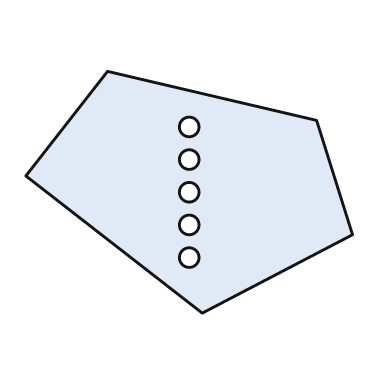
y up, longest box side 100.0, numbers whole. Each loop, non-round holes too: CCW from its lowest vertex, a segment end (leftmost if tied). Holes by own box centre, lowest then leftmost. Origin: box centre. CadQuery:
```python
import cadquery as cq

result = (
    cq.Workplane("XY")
    .moveTo(4.0, -37.0)
    .lineTo(50.0, -13.0)
    .lineTo(39.0, 22.0)
    .lineTo(-25.0, 37.0)
    .lineTo(-50.0, 5.0)
    .close()
    .moveTo(0.0, -20.0)
    .circle(3.0)
    .moveTo(0.0, -10.0)
    .circle(3.0)
    .moveTo(0.0, 0.0)
    .circle(3.0)
    .moveTo(0.0, 10.0)
    .circle(3.0)
    .moveTo(0.0, 20.0)
    .circle(3.0)
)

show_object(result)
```